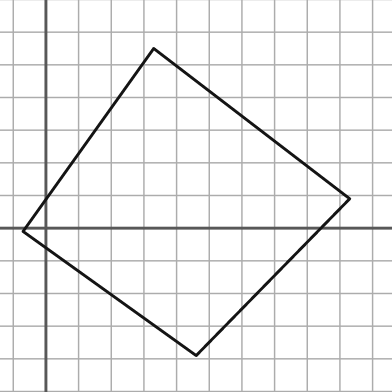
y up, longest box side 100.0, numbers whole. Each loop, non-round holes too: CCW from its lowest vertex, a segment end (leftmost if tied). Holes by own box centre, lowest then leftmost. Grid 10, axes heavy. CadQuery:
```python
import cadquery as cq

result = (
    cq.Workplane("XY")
    .moveTo(46.0, -39.0)
    .lineTo(93.0, 9.0)
    .lineTo(33.0, 55.0)
    .lineTo(-7.0, -1.0)
    .close()
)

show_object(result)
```